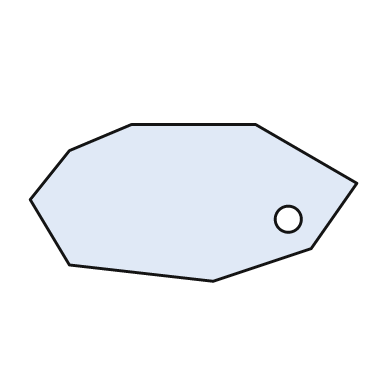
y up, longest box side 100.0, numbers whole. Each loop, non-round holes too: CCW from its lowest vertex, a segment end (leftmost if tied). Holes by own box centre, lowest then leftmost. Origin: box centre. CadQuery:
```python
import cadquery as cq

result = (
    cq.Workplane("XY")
    .moveTo(6.0, -24.0)
    .lineTo(36.0, -14.0)
    .lineTo(50.0, 6.0)
    .lineTo(19.0, 24.0)
    .lineTo(-19.0, 24.0)
    .lineTo(-38.0, 16.0)
    .lineTo(-50.0, 1.0)
    .lineTo(-38.0, -19.0)
    .close()
    .moveTo(29.0, -5.0)
    .circle(4.0)
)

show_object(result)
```